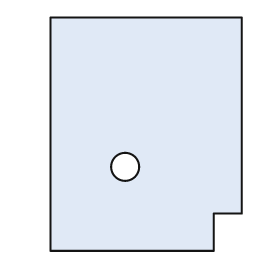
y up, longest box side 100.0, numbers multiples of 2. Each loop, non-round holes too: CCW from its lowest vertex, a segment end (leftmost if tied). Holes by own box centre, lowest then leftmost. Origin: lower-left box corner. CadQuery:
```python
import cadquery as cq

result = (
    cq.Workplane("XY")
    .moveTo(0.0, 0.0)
    .lineTo(70.0, 0.0)
    .lineTo(70.0, 16.0)
    .lineTo(82.0, 16.0)
    .lineTo(82.0, 100.0)
    .lineTo(0.0, 100.0)
    .close()
    .moveTo(32.0, 36.0)
    .circle(6.0)
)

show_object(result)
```